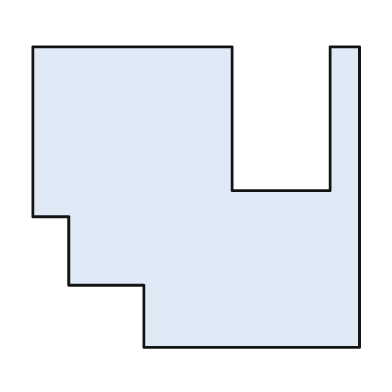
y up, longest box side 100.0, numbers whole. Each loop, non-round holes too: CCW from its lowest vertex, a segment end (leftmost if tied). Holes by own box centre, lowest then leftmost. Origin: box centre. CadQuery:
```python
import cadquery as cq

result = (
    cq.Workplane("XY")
    .moveTo(-16.0, -46.0)
    .lineTo(50.0, -46.0)
    .lineTo(50.0, 46.0)
    .lineTo(41.0, 46.0)
    .lineTo(41.0, 2.0)
    .lineTo(11.0, 2.0)
    .lineTo(11.0, 46.0)
    .lineTo(-50.0, 46.0)
    .lineTo(-50.0, -6.0)
    .lineTo(-39.0, -6.0)
    .lineTo(-39.0, -27.0)
    .lineTo(-16.0, -27.0)
    .close()
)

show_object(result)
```